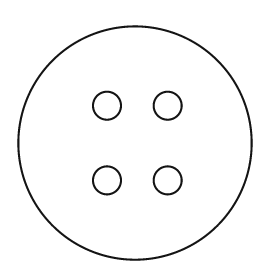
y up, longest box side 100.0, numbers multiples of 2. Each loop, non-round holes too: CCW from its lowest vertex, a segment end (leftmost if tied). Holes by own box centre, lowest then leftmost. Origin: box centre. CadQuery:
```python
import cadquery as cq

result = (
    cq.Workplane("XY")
    .moveTo(0.0, 0.0)
    .circle(50.0)
    .moveTo(-12.0, -16.0)
    .circle(6.0)
    .moveTo(14.0, -16.0)
    .circle(6.0)
    .moveTo(-12.0, 16.0)
    .circle(6.0)
    .moveTo(14.0, 16.0)
    .circle(6.0)
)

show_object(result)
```